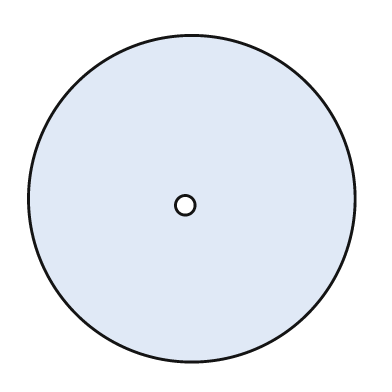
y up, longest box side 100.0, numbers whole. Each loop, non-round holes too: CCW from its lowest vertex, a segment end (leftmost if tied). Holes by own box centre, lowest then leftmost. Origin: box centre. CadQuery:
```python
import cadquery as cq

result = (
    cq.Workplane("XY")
    .moveTo(0.0, 0.0)
    .circle(50.0)
    .moveTo(-2.0, -2.0)
    .circle(3.0)
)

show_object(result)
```